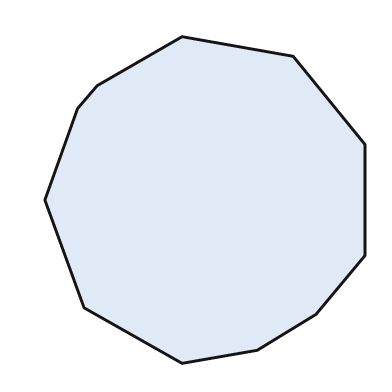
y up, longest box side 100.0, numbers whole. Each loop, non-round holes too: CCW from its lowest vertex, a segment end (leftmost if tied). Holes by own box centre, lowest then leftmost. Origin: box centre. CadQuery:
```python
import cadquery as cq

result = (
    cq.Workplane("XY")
    .moveTo(-7.0, -50.0)
    .lineTo(16.0, -46.0)
    .lineTo(34.0, -35.0)
    .lineTo(49.0, -17.0)
    .lineTo(49.0, 17.0)
    .lineTo(27.0, 44.0)
    .lineTo(-7.0, 50.0)
    .lineTo(-33.0, 35.0)
    .lineTo(-39.0, 28.0)
    .lineTo(-49.0, 0.0)
    .lineTo(-37.0, -33.0)
    .close()
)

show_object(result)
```